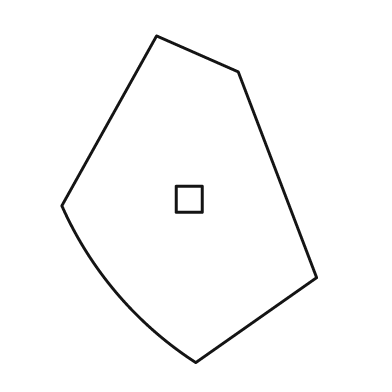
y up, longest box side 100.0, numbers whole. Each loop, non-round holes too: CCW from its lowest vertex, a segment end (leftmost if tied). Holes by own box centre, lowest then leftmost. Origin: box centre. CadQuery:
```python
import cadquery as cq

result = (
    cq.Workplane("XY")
    .moveTo(2.0, -50.0)
    .lineTo(39.0, -24.0)
    .lineTo(15.0, 39.0)
    .lineTo(-10.0, 50.0)
    .lineTo(-39.0, -2.0)
    .threePointArc((-22.0, -29.0), (2.0, -50.0))
    .close()
    .moveTo(-4.0, -4.0)
    .lineTo(4.0, -4.0)
    .lineTo(4.0, 4.0)
    .lineTo(-4.0, 4.0)
    .close()
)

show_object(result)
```